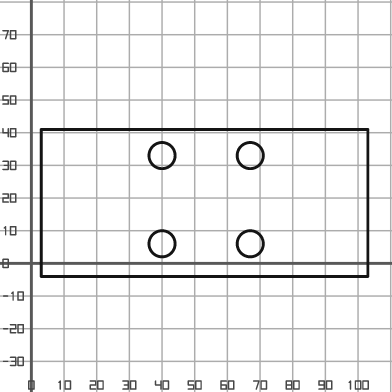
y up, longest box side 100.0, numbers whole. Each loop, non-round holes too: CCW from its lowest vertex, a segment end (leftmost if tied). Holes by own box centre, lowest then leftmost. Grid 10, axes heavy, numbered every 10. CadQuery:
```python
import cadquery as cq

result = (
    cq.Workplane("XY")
    .moveTo(3.0, -4.0)
    .lineTo(103.0, -4.0)
    .lineTo(103.0, 41.0)
    .lineTo(3.0, 41.0)
    .close()
    .moveTo(40.0, 6.0)
    .circle(4.0)
    .moveTo(67.0, 6.0)
    .circle(4.0)
    .moveTo(40.0, 33.0)
    .circle(4.0)
    .moveTo(67.0, 33.0)
    .circle(4.0)
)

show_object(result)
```